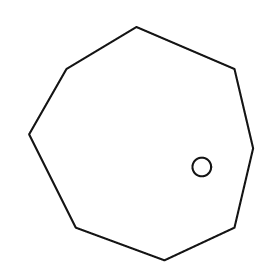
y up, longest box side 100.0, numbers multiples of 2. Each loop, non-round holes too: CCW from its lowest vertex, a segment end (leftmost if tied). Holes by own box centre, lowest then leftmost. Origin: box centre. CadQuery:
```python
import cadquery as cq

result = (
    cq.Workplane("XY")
    .moveTo(10.0, -50.0)
    .lineTo(40.0, -36.0)
    .lineTo(48.0, -2.0)
    .lineTo(40.0, 32.0)
    .lineTo(-2.0, 50.0)
    .lineTo(-32.0, 32.0)
    .lineTo(-48.0, 4.0)
    .lineTo(-28.0, -36.0)
    .close()
    .moveTo(26.0, -10.0)
    .circle(4.0)
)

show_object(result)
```